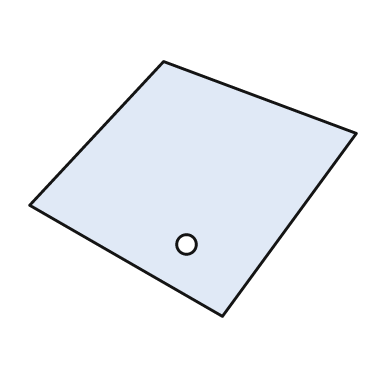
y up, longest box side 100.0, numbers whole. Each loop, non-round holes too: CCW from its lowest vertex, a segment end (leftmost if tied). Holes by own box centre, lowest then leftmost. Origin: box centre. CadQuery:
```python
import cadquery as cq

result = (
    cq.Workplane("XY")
    .moveTo(9.0, -39.0)
    .lineTo(50.0, 17.0)
    .lineTo(-9.0, 39.0)
    .lineTo(-50.0, -5.0)
    .close()
    .moveTo(-2.0, -17.0)
    .circle(3.0)
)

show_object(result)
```